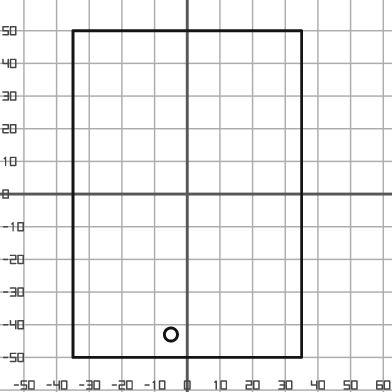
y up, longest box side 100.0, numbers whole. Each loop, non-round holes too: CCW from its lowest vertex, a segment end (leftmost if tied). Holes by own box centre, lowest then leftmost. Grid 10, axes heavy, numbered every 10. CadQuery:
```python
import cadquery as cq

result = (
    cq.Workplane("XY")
    .moveTo(-35.0, -50.0)
    .lineTo(35.0, -50.0)
    .lineTo(35.0, 50.0)
    .lineTo(-35.0, 50.0)
    .close()
    .moveTo(-5.0, -43.0)
    .circle(2.0)
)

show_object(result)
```